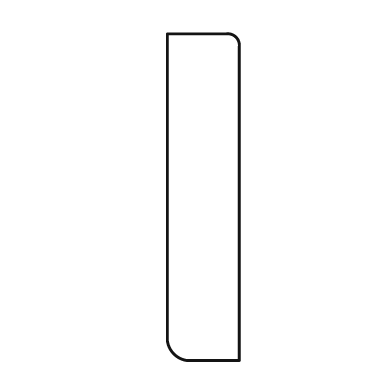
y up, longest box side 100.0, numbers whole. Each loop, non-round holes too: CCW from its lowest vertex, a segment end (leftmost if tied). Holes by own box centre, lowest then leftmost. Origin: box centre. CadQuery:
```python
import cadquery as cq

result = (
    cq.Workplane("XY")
    .moveTo(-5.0, -50.0)
    .lineTo(11.0, -50.0)
    .lineTo(11.0, 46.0)
    .threePointArc((10.0, 49.0), (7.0, 50.0))
    .lineTo(-11.0, 50.0)
    .lineTo(-11.0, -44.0)
    .threePointArc((-9.0, -48.0), (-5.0, -50.0))
    .close()
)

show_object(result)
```